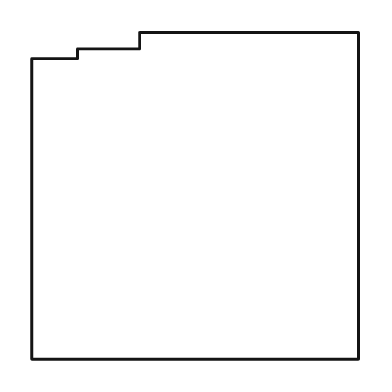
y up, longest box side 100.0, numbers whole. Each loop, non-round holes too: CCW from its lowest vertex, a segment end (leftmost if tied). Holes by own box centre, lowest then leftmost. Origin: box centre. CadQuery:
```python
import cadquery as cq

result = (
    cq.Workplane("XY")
    .moveTo(-50.0, -50.0)
    .lineTo(50.0, -50.0)
    .lineTo(50.0, 50.0)
    .lineTo(-17.0, 50.0)
    .lineTo(-17.0, 45.0)
    .lineTo(-36.0, 45.0)
    .lineTo(-36.0, 42.0)
    .lineTo(-50.0, 42.0)
    .close()
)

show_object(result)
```